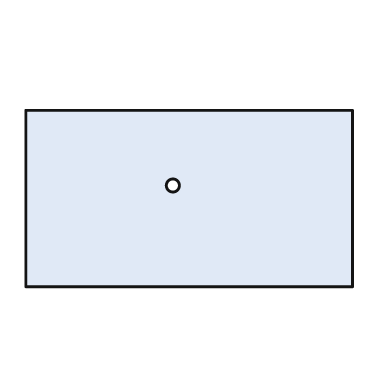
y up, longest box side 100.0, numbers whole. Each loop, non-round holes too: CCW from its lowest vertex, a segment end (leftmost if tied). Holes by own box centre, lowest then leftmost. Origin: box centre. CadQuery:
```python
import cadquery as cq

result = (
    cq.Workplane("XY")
    .moveTo(-50.0, -27.0)
    .lineTo(50.0, -27.0)
    .lineTo(50.0, 27.0)
    .lineTo(-50.0, 27.0)
    .close()
    .moveTo(-5.0, 4.0)
    .circle(2.0)
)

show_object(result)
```